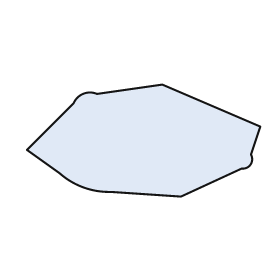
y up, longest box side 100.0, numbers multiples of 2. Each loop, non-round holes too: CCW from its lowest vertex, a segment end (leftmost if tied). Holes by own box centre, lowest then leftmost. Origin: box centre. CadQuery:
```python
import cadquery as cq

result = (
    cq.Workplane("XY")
    .moveTo(16.0, -24.0)
    .lineTo(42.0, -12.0)
    .threePointArc((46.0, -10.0), (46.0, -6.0))
    .lineTo(50.0, 6.0)
    .lineTo(8.0, 24.0)
    .lineTo(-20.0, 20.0)
    .threePointArc((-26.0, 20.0), (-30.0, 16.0))
    .lineTo(-50.0, -4.0)
    .lineTo(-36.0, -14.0)
    .threePointArc((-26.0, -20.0), (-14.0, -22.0))
    .close()
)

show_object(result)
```